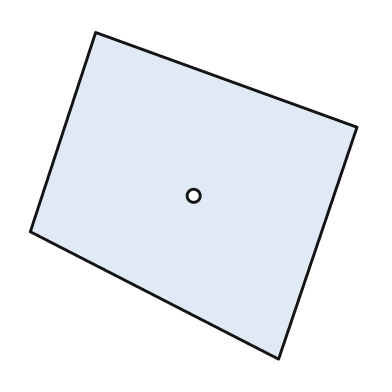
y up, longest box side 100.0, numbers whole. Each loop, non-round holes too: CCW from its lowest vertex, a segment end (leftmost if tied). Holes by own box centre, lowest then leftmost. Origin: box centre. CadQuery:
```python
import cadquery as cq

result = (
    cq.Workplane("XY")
    .moveTo(26.0, -50.0)
    .lineTo(50.0, 21.0)
    .lineTo(-30.0, 50.0)
    .lineTo(-50.0, -11.0)
    .close()
    .moveTo(0.0, 0.0)
    .circle(2.0)
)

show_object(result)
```